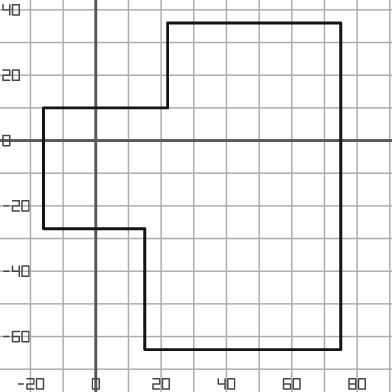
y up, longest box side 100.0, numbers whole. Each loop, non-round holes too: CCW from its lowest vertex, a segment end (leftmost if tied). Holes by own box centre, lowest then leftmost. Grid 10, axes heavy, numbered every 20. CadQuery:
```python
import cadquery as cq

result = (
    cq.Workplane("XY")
    .moveTo(15.0, -64.0)
    .lineTo(75.0, -64.0)
    .lineTo(75.0, 36.0)
    .lineTo(22.0, 36.0)
    .lineTo(22.0, 10.0)
    .lineTo(-16.0, 10.0)
    .lineTo(-16.0, -27.0)
    .lineTo(15.0, -27.0)
    .close()
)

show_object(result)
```